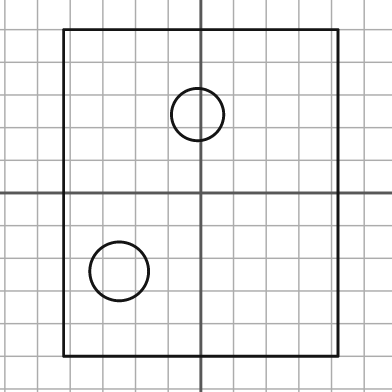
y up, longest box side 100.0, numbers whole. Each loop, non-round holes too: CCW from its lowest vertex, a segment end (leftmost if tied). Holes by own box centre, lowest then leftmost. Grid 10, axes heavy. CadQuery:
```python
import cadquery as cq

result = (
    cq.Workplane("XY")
    .moveTo(-42.0, -50.0)
    .lineTo(42.0, -50.0)
    .lineTo(42.0, 50.0)
    .lineTo(-42.0, 50.0)
    .close()
    .moveTo(-25.0, -24.0)
    .circle(9.0)
    .moveTo(-1.0, 24.0)
    .circle(8.0)
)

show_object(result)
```